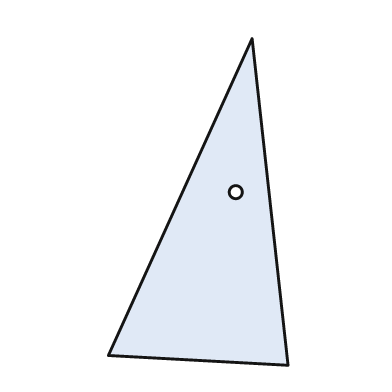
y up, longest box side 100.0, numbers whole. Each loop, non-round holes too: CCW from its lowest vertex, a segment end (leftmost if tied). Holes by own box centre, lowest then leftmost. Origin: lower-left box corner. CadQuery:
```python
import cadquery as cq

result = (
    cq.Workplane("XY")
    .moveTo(55.0, 0.0)
    .lineTo(44.0, 100.0)
    .lineTo(0.0, 3.0)
    .close()
    .moveTo(39.0, 53.0)
    .circle(2.0)
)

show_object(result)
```